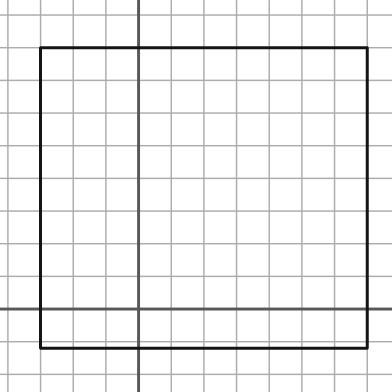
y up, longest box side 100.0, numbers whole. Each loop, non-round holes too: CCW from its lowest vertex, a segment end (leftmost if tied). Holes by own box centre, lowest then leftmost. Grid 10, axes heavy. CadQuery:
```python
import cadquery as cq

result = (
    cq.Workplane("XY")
    .moveTo(-30.0, -12.0)
    .lineTo(70.0, -12.0)
    .lineTo(70.0, 80.0)
    .lineTo(-30.0, 80.0)
    .close()
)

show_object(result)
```